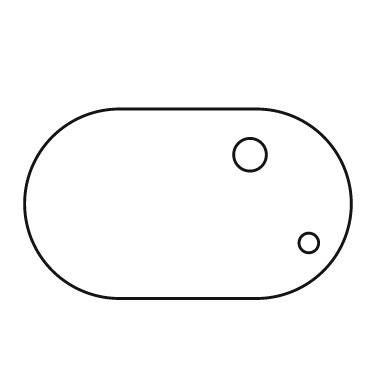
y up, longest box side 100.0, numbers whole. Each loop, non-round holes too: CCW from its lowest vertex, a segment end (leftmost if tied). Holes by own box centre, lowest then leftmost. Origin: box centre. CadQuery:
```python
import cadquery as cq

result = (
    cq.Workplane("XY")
    .moveTo(-21.0, -29.0)
    .lineTo(21.0, -29.0)
    .threePointArc((50.0, 0.0), (21.0, 29.0))
    .lineTo(-21.0, 29.0)
    .threePointArc((-50.0, 0.0), (-21.0, -29.0))
    .close()
    .moveTo(37.0, -12.0)
    .circle(3.0)
    .moveTo(19.0, 15.0)
    .circle(5.0)
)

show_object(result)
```